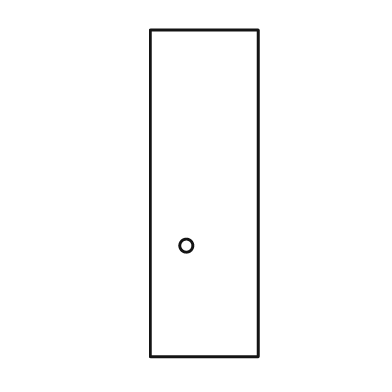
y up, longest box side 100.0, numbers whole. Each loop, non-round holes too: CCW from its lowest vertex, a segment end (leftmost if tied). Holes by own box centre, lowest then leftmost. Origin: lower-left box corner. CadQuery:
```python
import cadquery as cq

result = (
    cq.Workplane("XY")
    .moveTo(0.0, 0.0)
    .lineTo(33.0, 0.0)
    .lineTo(33.0, 100.0)
    .lineTo(0.0, 100.0)
    .close()
    .moveTo(11.0, 34.0)
    .circle(2.0)
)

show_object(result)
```